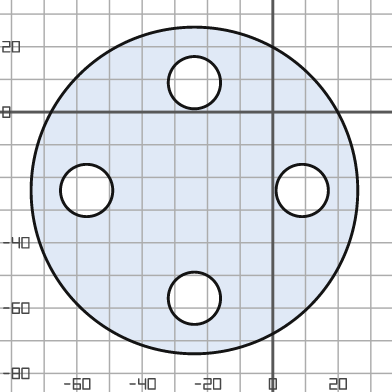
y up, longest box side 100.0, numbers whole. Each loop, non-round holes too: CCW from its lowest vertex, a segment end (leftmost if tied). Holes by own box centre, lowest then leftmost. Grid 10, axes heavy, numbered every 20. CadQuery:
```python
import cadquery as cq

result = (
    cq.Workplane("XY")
    .moveTo(-24.0, -24.0)
    .circle(50.0)
    .moveTo(-24.0, -57.0)
    .circle(8.0)
    .moveTo(-57.0, -24.0)
    .circle(8.0)
    .moveTo(9.0, -24.0)
    .circle(8.0)
    .moveTo(-24.0, 9.0)
    .circle(8.0)
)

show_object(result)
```